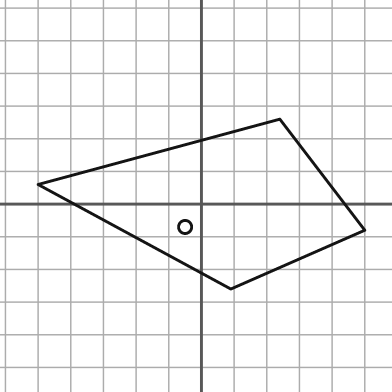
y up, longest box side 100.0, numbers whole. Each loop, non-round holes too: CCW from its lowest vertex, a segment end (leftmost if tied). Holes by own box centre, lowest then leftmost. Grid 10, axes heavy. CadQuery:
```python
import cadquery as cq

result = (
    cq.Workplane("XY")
    .moveTo(9.0, -26.0)
    .lineTo(50.0, -8.0)
    .lineTo(24.0, 26.0)
    .lineTo(-50.0, 6.0)
    .close()
    .moveTo(-5.0, -7.0)
    .circle(2.0)
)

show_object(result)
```